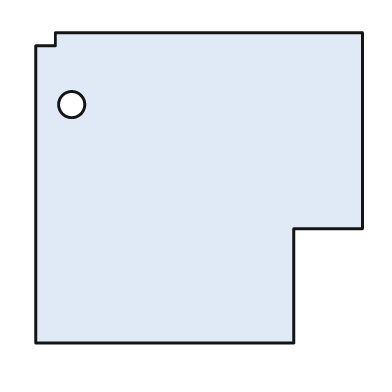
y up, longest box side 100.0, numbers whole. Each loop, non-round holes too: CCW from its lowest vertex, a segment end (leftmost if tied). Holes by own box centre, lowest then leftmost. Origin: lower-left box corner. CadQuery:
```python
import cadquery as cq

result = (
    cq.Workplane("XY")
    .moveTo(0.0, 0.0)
    .lineTo(79.0, 0.0)
    .lineTo(79.0, 35.0)
    .lineTo(100.0, 35.0)
    .lineTo(100.0, 95.0)
    .lineTo(6.0, 95.0)
    .lineTo(6.0, 91.0)
    .lineTo(0.0, 91.0)
    .close()
    .moveTo(11.0, 73.0)
    .circle(4.0)
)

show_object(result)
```